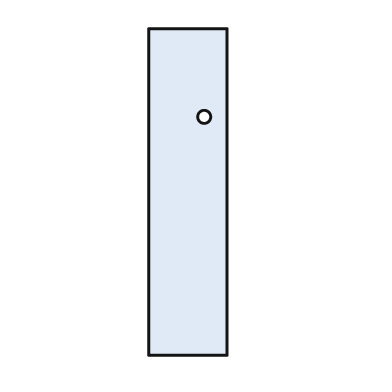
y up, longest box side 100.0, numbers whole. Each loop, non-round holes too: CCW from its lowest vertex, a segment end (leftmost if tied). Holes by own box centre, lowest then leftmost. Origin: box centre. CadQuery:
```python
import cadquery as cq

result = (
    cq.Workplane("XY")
    .moveTo(-12.0, -50.0)
    .lineTo(12.0, -50.0)
    .lineTo(12.0, 50.0)
    .lineTo(-12.0, 50.0)
    .close()
    .moveTo(5.0, 23.0)
    .circle(2.0)
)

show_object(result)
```